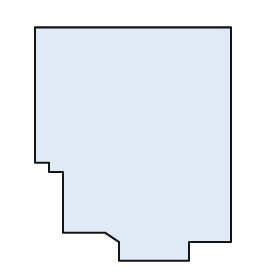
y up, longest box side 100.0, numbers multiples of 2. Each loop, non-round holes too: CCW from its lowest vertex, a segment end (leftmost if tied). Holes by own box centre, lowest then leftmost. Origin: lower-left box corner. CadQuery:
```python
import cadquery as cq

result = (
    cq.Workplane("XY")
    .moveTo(36.0, 0.0)
    .lineTo(66.0, 0.0)
    .lineTo(66.0, 8.0)
    .lineTo(84.0, 8.0)
    .lineTo(84.0, 100.0)
    .lineTo(0.0, 100.0)
    .lineTo(0.0, 42.0)
    .lineTo(6.0, 42.0)
    .lineTo(6.0, 38.0)
    .lineTo(12.0, 38.0)
    .lineTo(12.0, 12.0)
    .lineTo(30.0, 12.0)
    .lineTo(36.0, 8.0)
    .close()
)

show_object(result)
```